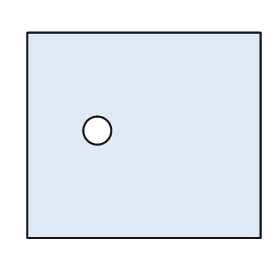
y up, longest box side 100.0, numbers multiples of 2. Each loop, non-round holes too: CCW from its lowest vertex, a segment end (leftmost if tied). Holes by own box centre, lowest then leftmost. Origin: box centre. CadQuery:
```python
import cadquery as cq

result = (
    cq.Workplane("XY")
    .moveTo(-50.0, -44.0)
    .lineTo(50.0, -44.0)
    .lineTo(50.0, 44.0)
    .lineTo(-50.0, 44.0)
    .close()
    .moveTo(-20.0, 2.0)
    .circle(6.0)
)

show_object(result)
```